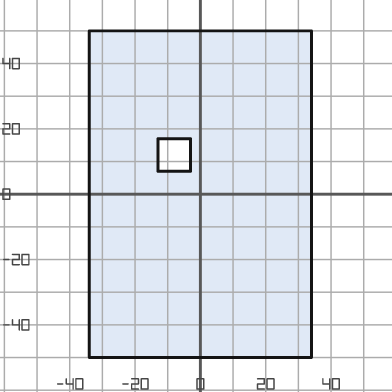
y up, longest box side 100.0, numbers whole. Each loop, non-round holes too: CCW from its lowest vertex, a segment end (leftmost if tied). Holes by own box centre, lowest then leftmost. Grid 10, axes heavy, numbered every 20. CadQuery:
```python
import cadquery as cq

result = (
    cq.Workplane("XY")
    .moveTo(-34.0, -50.0)
    .lineTo(34.0, -50.0)
    .lineTo(34.0, 50.0)
    .lineTo(-34.0, 50.0)
    .close()
    .moveTo(-13.0, 7.0)
    .lineTo(-3.0, 7.0)
    .lineTo(-3.0, 17.0)
    .lineTo(-13.0, 17.0)
    .close()
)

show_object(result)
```